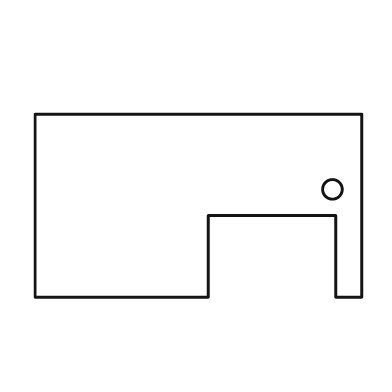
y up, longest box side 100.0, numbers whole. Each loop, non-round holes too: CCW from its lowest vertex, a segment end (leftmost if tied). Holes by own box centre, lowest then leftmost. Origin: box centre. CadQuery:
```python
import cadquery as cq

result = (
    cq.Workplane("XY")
    .moveTo(-50.0, -28.0)
    .lineTo(3.0, -28.0)
    .lineTo(3.0, -3.0)
    .lineTo(42.0, -3.0)
    .lineTo(42.0, -28.0)
    .lineTo(50.0, -28.0)
    .lineTo(50.0, 28.0)
    .lineTo(-50.0, 28.0)
    .close()
    .moveTo(41.0, 5.0)
    .circle(3.0)
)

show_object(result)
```